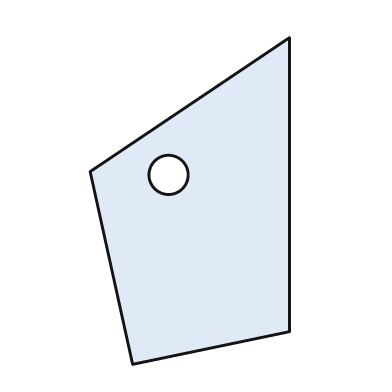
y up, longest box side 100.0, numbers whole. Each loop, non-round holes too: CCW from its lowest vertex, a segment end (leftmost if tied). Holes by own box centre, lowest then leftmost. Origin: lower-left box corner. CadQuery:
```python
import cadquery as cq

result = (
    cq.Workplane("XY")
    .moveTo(13.0, 0.0)
    .lineTo(61.0, 10.0)
    .lineTo(61.0, 100.0)
    .lineTo(0.0, 59.0)
    .close()
    .moveTo(24.0, 58.0)
    .circle(6.0)
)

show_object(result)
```